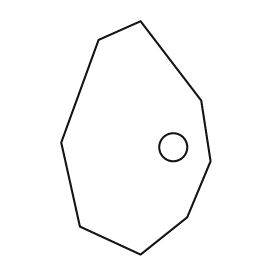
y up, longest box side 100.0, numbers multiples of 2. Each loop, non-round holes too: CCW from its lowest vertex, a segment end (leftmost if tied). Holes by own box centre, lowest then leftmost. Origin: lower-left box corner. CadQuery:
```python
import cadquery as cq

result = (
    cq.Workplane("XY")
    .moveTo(34.0, 0.0)
    .lineTo(54.0, 16.0)
    .lineTo(64.0, 40.0)
    .lineTo(60.0, 66.0)
    .lineTo(34.0, 100.0)
    .lineTo(16.0, 92.0)
    .lineTo(0.0, 48.0)
    .lineTo(8.0, 12.0)
    .close()
    .moveTo(48.0, 46.0)
    .circle(6.0)
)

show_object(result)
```